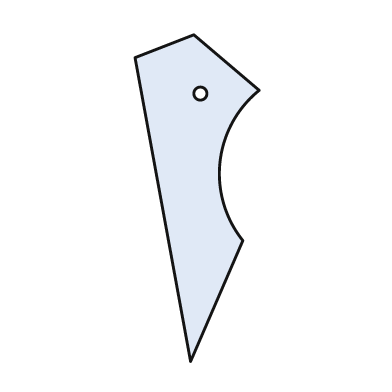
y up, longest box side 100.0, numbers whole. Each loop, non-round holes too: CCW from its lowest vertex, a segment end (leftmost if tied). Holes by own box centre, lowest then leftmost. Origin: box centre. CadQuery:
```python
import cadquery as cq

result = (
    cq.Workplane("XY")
    .moveTo(-2.0, -50.0)
    .lineTo(14.0, -13.0)
    .threePointArc((7.0, 11.0), (19.0, 33.0))
    .lineTo(-1.0, 50.0)
    .lineTo(-19.0, 43.0)
    .close()
    .moveTo(1.0, 32.0)
    .circle(2.0)
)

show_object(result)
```